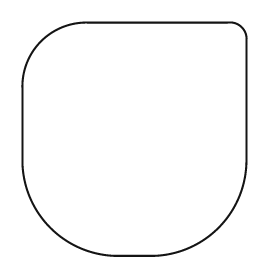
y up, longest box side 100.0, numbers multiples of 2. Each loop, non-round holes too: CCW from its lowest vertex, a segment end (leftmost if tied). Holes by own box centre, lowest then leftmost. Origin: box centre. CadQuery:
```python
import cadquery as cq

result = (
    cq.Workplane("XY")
    .moveTo(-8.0, -50.0)
    .lineTo(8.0, -50.0)
    .threePointArc((36.0, -38.0), (48.0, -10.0))
    .lineTo(48.0, 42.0)
    .threePointArc((46.0, 48.0), (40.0, 50.0))
    .lineTo(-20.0, 50.0)
    .threePointArc((-40.0, 42.0), (-48.0, 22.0))
    .lineTo(-48.0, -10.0)
    .threePointArc((-36.0, -38.0), (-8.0, -50.0))
    .close()
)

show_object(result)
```